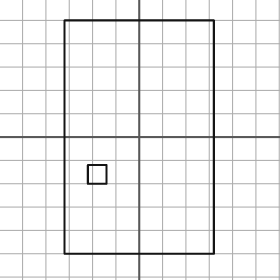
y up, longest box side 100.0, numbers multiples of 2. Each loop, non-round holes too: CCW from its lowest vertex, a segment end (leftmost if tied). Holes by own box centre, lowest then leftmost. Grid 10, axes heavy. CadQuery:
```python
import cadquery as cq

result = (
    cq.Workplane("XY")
    .moveTo(-32.0, -50.0)
    .lineTo(32.0, -50.0)
    .lineTo(32.0, 50.0)
    .lineTo(-32.0, 50.0)
    .close()
    .moveTo(-22.0, -20.0)
    .lineTo(-14.0, -20.0)
    .lineTo(-14.0, -12.0)
    .lineTo(-22.0, -12.0)
    .close()
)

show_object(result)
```